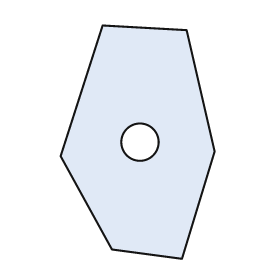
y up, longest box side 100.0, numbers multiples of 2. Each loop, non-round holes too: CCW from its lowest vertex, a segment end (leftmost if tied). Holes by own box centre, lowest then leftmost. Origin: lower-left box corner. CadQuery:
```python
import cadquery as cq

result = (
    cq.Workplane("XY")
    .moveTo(52.0, 0.0)
    .lineTo(66.0, 46.0)
    .lineTo(54.0, 98.0)
    .lineTo(18.0, 100.0)
    .lineTo(0.0, 44.0)
    .lineTo(22.0, 4.0)
    .close()
    .moveTo(34.0, 50.0)
    .circle(8.0)
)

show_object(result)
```